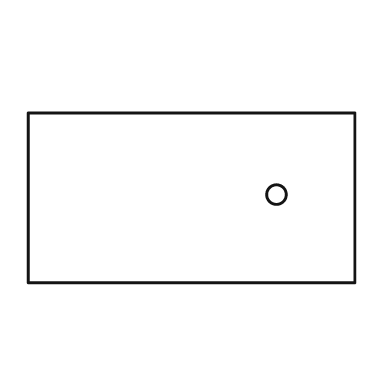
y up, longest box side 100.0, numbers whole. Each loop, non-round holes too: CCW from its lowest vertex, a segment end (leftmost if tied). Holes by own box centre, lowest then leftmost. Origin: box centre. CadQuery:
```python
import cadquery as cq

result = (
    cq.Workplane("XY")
    .moveTo(-50.0, -26.0)
    .lineTo(50.0, -26.0)
    .lineTo(50.0, 26.0)
    .lineTo(-50.0, 26.0)
    .close()
    .moveTo(26.0, 1.0)
    .circle(3.0)
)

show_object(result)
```